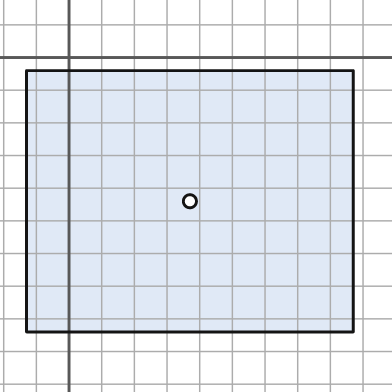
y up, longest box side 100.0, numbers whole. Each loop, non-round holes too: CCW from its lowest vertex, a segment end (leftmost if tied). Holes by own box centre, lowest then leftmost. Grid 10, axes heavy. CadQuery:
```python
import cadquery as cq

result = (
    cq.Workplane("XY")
    .moveTo(-13.0, -84.0)
    .lineTo(87.0, -84.0)
    .lineTo(87.0, -4.0)
    .lineTo(-13.0, -4.0)
    .close()
    .moveTo(37.0, -44.0)
    .circle(2.0)
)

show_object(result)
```